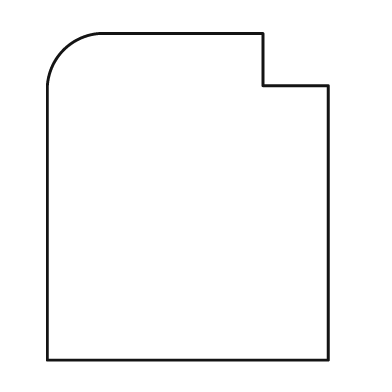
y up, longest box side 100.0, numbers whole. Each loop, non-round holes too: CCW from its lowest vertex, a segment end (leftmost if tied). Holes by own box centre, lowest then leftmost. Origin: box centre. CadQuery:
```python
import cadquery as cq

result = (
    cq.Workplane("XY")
    .moveTo(-43.0, -50.0)
    .lineTo(43.0, -50.0)
    .lineTo(43.0, 34.0)
    .lineTo(23.0, 34.0)
    .lineTo(23.0, 50.0)
    .lineTo(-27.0, 50.0)
    .threePointArc((-38.0, 45.0), (-43.0, 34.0))
    .close()
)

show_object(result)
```